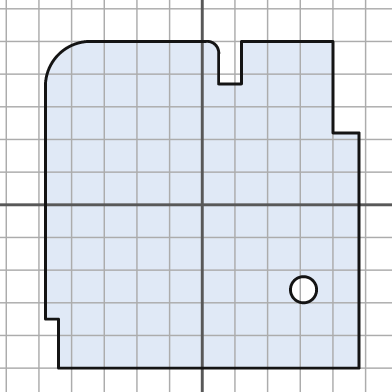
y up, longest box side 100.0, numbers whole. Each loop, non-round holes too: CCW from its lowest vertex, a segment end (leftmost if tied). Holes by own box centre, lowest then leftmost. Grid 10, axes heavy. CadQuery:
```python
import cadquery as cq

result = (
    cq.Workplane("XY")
    .moveTo(-44.0, -50.0)
    .lineTo(48.0, -50.0)
    .lineTo(48.0, 22.0)
    .lineTo(40.0, 22.0)
    .lineTo(40.0, 50.0)
    .lineTo(12.0, 50.0)
    .lineTo(12.0, 37.0)
    .lineTo(5.0, 37.0)
    .lineTo(5.0, 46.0)
    .threePointArc((4.0, 49.0), (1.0, 50.0))
    .lineTo(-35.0, 50.0)
    .threePointArc((-44.0, 46.0), (-48.0, 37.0))
    .lineTo(-48.0, -35.0)
    .lineTo(-44.0, -35.0)
    .close()
    .moveTo(31.0, -26.0)
    .circle(4.0)
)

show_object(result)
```